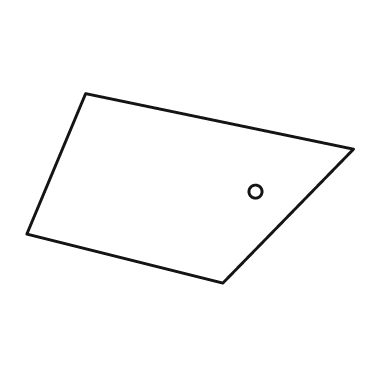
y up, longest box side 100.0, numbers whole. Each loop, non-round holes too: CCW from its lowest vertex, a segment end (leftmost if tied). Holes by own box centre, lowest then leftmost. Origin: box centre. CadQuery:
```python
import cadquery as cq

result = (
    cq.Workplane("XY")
    .moveTo(10.0, -29.0)
    .lineTo(50.0, 12.0)
    .lineTo(-32.0, 29.0)
    .lineTo(-50.0, -14.0)
    .close()
    .moveTo(20.0, -1.0)
    .circle(2.0)
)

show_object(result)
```